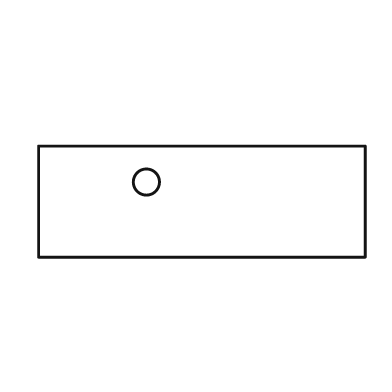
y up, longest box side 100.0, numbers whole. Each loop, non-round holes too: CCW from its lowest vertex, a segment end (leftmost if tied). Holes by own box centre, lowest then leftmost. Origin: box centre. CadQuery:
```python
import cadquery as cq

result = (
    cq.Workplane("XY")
    .moveTo(-50.0, -17.0)
    .lineTo(50.0, -17.0)
    .lineTo(50.0, 17.0)
    .lineTo(-50.0, 17.0)
    .close()
    .moveTo(-17.0, 6.0)
    .circle(4.0)
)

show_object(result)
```